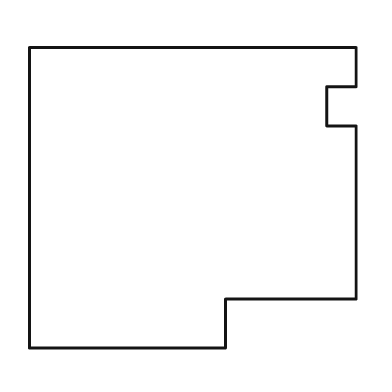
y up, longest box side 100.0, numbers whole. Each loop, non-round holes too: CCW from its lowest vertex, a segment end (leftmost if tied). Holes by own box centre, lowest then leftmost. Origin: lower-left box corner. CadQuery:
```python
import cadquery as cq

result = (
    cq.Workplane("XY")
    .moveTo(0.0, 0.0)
    .lineTo(60.0, 0.0)
    .lineTo(60.0, 15.0)
    .lineTo(100.0, 15.0)
    .lineTo(100.0, 68.0)
    .lineTo(91.0, 68.0)
    .lineTo(91.0, 80.0)
    .lineTo(100.0, 80.0)
    .lineTo(100.0, 92.0)
    .lineTo(0.0, 92.0)
    .close()
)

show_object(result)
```